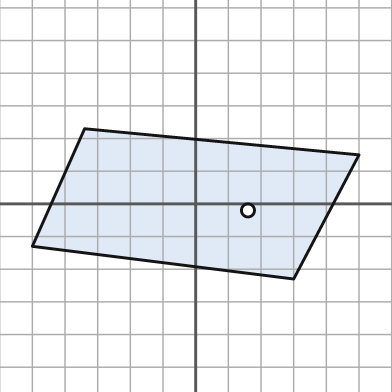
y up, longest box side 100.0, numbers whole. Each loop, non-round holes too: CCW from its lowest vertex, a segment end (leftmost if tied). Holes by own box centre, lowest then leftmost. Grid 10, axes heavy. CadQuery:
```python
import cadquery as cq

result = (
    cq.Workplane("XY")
    .moveTo(30.0, -23.0)
    .lineTo(50.0, 15.0)
    .lineTo(-34.0, 23.0)
    .lineTo(-50.0, -13.0)
    .close()
    .moveTo(16.0, -2.0)
    .circle(2.0)
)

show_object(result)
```